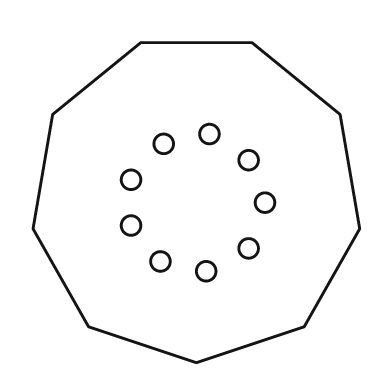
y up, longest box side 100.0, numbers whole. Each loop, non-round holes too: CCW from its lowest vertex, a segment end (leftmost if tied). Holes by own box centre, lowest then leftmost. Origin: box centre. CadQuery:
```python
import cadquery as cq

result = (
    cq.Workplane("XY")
    .moveTo(0.0, -49.0)
    .lineTo(33.0, -38.0)
    .lineTo(50.0, -8.0)
    .lineTo(44.0, 27.0)
    .lineTo(17.0, 49.0)
    .lineTo(-17.0, 49.0)
    .lineTo(-44.0, 27.0)
    .lineTo(-50.0, -8.0)
    .lineTo(-33.0, -38.0)
    .close()
    .moveTo(3.0, -21.0)
    .circle(3.0)
    .moveTo(-11.0, -18.0)
    .circle(3.0)
    .moveTo(16.0, -14.0)
    .circle(3.0)
    .moveTo(-20.0, -7.0)
    .circle(3.0)
    .moveTo(21.0, 0.0)
    .circle(3.0)
    .moveTo(-20.0, 7.0)
    .circle(3.0)
    .moveTo(16.0, 13.0)
    .circle(3.0)
    .moveTo(-10.0, 18.0)
    .circle(3.0)
    .moveTo(4.0, 21.0)
    .circle(3.0)
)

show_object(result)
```